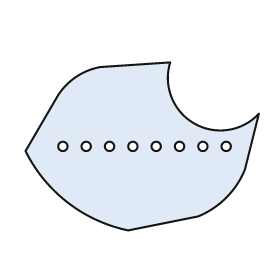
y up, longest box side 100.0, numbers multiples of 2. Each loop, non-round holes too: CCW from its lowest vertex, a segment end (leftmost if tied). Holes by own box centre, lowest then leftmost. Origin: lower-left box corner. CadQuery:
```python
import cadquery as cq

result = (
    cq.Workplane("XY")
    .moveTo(44.0, 0.0)
    .lineTo(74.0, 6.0)
    .threePointArc((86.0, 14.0), (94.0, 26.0))
    .lineTo(100.0, 50.0)
    .threePointArc((72.0, 46.0), (62.0, 72.0))
    .lineTo(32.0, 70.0)
    .threePointArc((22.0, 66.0), (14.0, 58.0))
    .lineTo(0.0, 34.0)
    .threePointArc((18.0, 12.0), (44.0, 0.0))
    .close()
    .moveTo(16.0, 36.0)
    .circle(2.0)
    .moveTo(26.0, 36.0)
    .circle(2.0)
    .moveTo(36.0, 36.0)
    .circle(2.0)
    .moveTo(46.0, 36.0)
    .circle(2.0)
    .moveTo(56.0, 36.0)
    .circle(2.0)
    .moveTo(66.0, 36.0)
    .circle(2.0)
    .moveTo(76.0, 36.0)
    .circle(2.0)
    .moveTo(86.0, 36.0)
    .circle(2.0)
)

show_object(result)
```